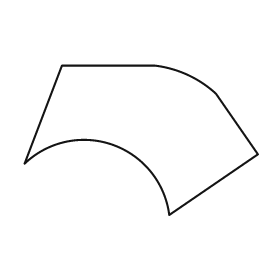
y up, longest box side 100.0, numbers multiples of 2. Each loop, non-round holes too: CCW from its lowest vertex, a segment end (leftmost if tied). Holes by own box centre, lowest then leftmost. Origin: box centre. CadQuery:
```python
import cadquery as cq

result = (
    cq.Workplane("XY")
    .moveTo(12.0, -32.0)
    .lineTo(50.0, -6.0)
    .lineTo(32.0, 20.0)
    .threePointArc((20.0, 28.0), (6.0, 32.0))
    .lineTo(-34.0, 32.0)
    .lineTo(-50.0, -10.0)
    .threePointArc((-12.0, -2.0), (12.0, -32.0))
    .close()
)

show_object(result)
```